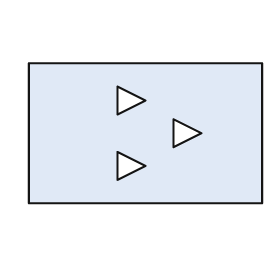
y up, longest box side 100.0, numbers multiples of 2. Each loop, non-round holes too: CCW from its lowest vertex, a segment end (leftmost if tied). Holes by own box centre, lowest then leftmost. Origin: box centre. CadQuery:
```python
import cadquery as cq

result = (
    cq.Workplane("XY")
    .moveTo(-50.0, -30.0)
    .lineTo(50.0, -30.0)
    .lineTo(50.0, 30.0)
    .lineTo(-50.0, 30.0)
    .close()
    .moveTo(-12.0, -20.0)
    .lineTo(0.0, -14.0)
    .lineTo(-12.0, -8.0)
    .close()
    .moveTo(12.0, -6.0)
    .lineTo(24.0, 0.0)
    .lineTo(12.0, 6.0)
    .close()
    .moveTo(-12.0, 8.0)
    .lineTo(0.0, 14.0)
    .lineTo(-12.0, 20.0)
    .close()
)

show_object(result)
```